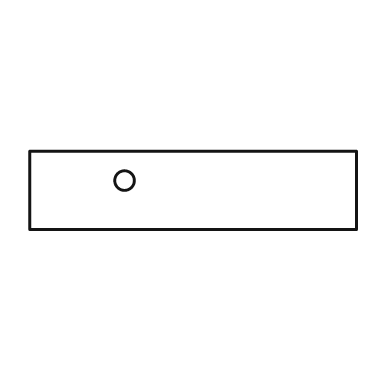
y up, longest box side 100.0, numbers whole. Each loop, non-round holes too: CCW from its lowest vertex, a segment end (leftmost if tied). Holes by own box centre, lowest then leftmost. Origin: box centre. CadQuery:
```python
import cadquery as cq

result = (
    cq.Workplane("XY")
    .moveTo(-50.0, -12.0)
    .lineTo(50.0, -12.0)
    .lineTo(50.0, 12.0)
    .lineTo(-50.0, 12.0)
    .close()
    .moveTo(-21.0, 3.0)
    .circle(3.0)
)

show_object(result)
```